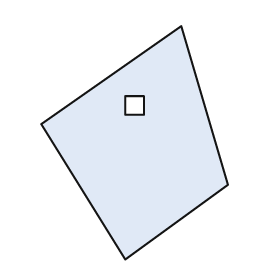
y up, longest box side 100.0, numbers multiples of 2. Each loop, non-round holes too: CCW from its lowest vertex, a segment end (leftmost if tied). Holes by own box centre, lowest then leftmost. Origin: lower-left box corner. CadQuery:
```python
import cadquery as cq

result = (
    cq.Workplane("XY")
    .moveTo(36.0, 0.0)
    .lineTo(80.0, 32.0)
    .lineTo(60.0, 100.0)
    .lineTo(0.0, 58.0)
    .close()
    .moveTo(36.0, 62.0)
    .lineTo(44.0, 62.0)
    .lineTo(44.0, 70.0)
    .lineTo(36.0, 70.0)
    .close()
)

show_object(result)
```